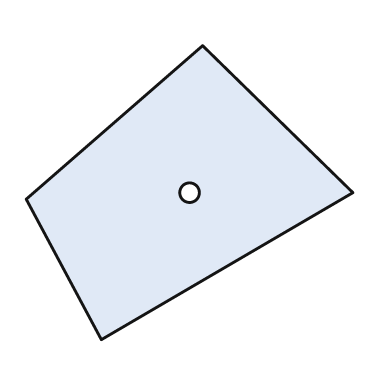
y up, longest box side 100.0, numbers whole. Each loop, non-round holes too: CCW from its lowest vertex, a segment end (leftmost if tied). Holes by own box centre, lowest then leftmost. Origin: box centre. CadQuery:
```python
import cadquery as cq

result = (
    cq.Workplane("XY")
    .moveTo(-27.0, -45.0)
    .lineTo(50.0, 0.0)
    .lineTo(4.0, 45.0)
    .lineTo(-50.0, -2.0)
    .close()
    .moveTo(0.0, 0.0)
    .circle(3.0)
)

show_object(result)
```